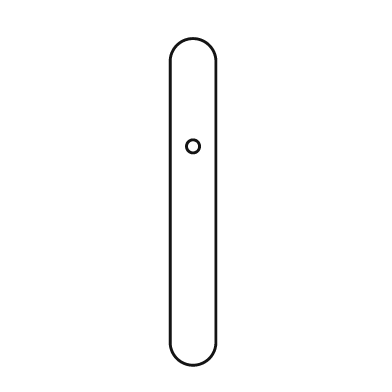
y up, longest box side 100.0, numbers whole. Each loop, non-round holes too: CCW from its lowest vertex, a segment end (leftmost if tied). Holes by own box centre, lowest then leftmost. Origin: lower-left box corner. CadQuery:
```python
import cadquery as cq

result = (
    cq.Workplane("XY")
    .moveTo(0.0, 7.0)
    .threePointArc((7.0, 0.0), (14.0, 7.0))
    .lineTo(14.0, 93.0)
    .threePointArc((7.0, 100.0), (0.0, 93.0))
    .close()
    .moveTo(7.0, 67.0)
    .circle(2.0)
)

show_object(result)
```